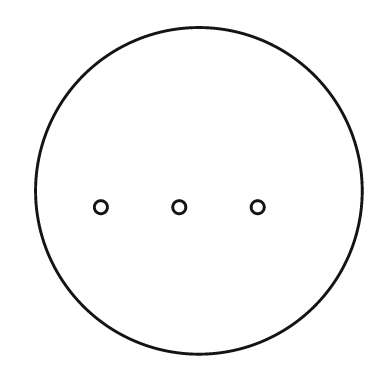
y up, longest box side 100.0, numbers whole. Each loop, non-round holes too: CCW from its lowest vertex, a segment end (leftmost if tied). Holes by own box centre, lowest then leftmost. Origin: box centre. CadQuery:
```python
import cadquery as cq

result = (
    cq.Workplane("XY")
    .moveTo(0.0, 0.0)
    .circle(50.0)
    .moveTo(-30.0, -5.0)
    .circle(2.0)
    .moveTo(-6.0, -5.0)
    .circle(2.0)
    .moveTo(18.0, -5.0)
    .circle(2.0)
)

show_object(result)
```